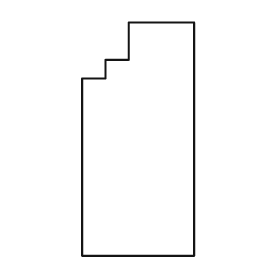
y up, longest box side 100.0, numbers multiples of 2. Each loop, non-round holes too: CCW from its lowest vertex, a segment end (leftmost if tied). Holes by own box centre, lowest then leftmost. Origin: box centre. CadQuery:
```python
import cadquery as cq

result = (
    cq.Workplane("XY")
    .moveTo(-24.0, -50.0)
    .lineTo(24.0, -50.0)
    .lineTo(24.0, 50.0)
    .lineTo(-4.0, 50.0)
    .lineTo(-4.0, 34.0)
    .lineTo(-14.0, 34.0)
    .lineTo(-14.0, 26.0)
    .lineTo(-24.0, 26.0)
    .close()
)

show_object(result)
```